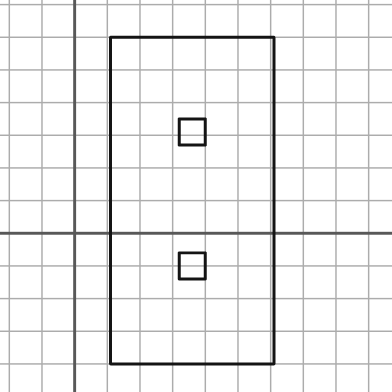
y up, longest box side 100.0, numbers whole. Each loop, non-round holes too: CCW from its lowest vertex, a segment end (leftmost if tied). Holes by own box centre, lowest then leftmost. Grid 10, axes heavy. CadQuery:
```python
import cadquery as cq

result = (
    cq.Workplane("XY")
    .moveTo(11.0, -40.0)
    .lineTo(61.0, -40.0)
    .lineTo(61.0, 60.0)
    .lineTo(11.0, 60.0)
    .close()
    .moveTo(32.0, -14.0)
    .lineTo(40.0, -14.0)
    .lineTo(40.0, -6.0)
    .lineTo(32.0, -6.0)
    .close()
    .moveTo(32.0, 27.0)
    .lineTo(40.0, 27.0)
    .lineTo(40.0, 35.0)
    .lineTo(32.0, 35.0)
    .close()
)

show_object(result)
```